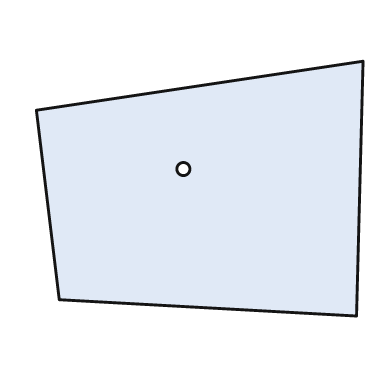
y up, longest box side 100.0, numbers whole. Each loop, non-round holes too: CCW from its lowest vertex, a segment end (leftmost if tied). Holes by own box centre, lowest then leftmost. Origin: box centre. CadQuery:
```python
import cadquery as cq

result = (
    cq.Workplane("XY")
    .moveTo(48.0, -39.0)
    .lineTo(50.0, 39.0)
    .lineTo(-50.0, 24.0)
    .lineTo(-43.0, -34.0)
    .close()
    .moveTo(-5.0, 6.0)
    .circle(2.0)
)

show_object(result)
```